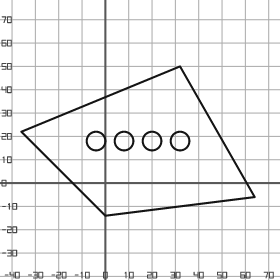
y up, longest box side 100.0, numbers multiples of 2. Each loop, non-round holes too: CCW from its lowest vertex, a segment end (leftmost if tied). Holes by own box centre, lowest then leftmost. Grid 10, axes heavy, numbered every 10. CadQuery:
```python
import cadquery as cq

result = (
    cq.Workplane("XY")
    .moveTo(0.0, -14.0)
    .lineTo(64.0, -6.0)
    .lineTo(32.0, 50.0)
    .lineTo(-36.0, 22.0)
    .close()
    .moveTo(-4.0, 18.0)
    .circle(4.0)
    .moveTo(8.0, 18.0)
    .circle(4.0)
    .moveTo(20.0, 18.0)
    .circle(4.0)
    .moveTo(32.0, 18.0)
    .circle(4.0)
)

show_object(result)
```